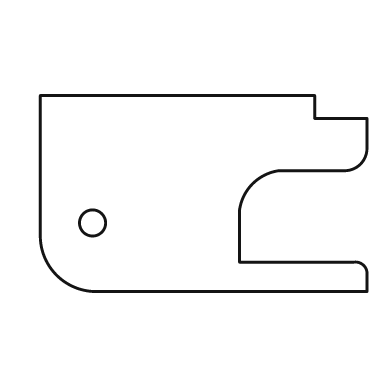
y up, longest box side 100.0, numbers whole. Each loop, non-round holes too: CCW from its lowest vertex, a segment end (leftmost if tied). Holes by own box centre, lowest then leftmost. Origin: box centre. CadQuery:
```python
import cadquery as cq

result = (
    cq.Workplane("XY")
    .moveTo(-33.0, -30.0)
    .lineTo(50.0, -30.0)
    .lineTo(50.0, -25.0)
    .threePointArc((49.0, -22.0), (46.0, -21.0))
    .lineTo(11.0, -21.0)
    .lineTo(11.0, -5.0)
    .threePointArc((15.0, 3.0), (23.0, 7.0))
    .lineTo(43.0, 7.0)
    .threePointArc((48.0, 9.0), (50.0, 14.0))
    .lineTo(50.0, 23.0)
    .lineTo(34.0, 23.0)
    .lineTo(34.0, 30.0)
    .lineTo(-50.0, 30.0)
    .lineTo(-50.0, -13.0)
    .threePointArc((-45.0, -25.0), (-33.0, -30.0))
    .close()
    .moveTo(-34.0, -9.0)
    .circle(4.0)
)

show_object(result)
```